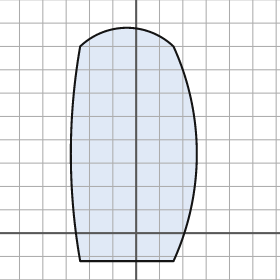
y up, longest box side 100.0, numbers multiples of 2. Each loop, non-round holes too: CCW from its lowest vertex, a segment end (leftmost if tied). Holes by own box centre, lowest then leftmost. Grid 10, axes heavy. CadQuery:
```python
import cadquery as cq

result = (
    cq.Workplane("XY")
    .moveTo(-24.0, -12.0)
    .lineTo(16.0, -12.0)
    .threePointArc((26.0, 34.0), (16.0, 80.0))
    .threePointArc((-4.0, 88.0), (-24.0, 80.0))
    .threePointArc((-28.0, 34.0), (-24.0, -12.0))
    .close()
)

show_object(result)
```